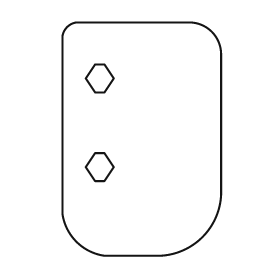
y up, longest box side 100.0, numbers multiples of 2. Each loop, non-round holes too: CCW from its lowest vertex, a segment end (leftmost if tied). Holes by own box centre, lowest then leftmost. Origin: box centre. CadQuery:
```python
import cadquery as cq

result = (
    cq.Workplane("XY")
    .moveTo(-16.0, -50.0)
    .lineTo(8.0, -50.0)
    .threePointArc((26.0, -42.0), (34.0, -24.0))
    .lineTo(34.0, 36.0)
    .threePointArc((30.0, 46.0), (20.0, 50.0))
    .lineTo(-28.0, 50.0)
    .threePointArc((-32.0, 48.0), (-34.0, 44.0))
    .lineTo(-34.0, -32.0)
    .threePointArc((-28.0, -44.0), (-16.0, -50.0))
    .close()
    .moveTo(-20.0, -18.0)
    .lineTo(-16.0, -18.0)
    .lineTo(-12.0, -12.0)
    .lineTo(-16.0, -6.0)
    .lineTo(-20.0, -6.0)
    .lineTo(-24.0, -12.0)
    .close()
    .moveTo(-20.0, 20.0)
    .lineTo(-16.0, 20.0)
    .lineTo(-12.0, 26.0)
    .lineTo(-16.0, 32.0)
    .lineTo(-20.0, 32.0)
    .lineTo(-24.0, 26.0)
    .close()
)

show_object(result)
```